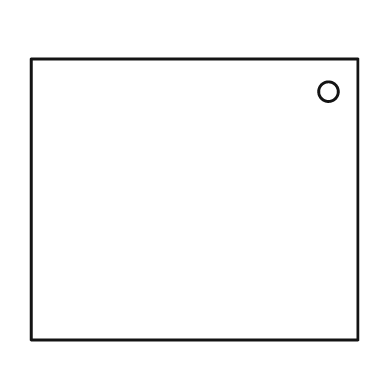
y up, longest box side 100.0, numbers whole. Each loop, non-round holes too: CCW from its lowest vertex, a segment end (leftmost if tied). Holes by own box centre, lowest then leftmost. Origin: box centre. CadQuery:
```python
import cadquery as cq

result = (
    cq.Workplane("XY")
    .moveTo(-50.0, -43.0)
    .lineTo(50.0, -43.0)
    .lineTo(50.0, 43.0)
    .lineTo(-50.0, 43.0)
    .close()
    .moveTo(41.0, 33.0)
    .circle(3.0)
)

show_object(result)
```